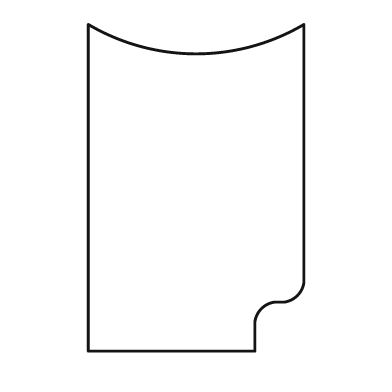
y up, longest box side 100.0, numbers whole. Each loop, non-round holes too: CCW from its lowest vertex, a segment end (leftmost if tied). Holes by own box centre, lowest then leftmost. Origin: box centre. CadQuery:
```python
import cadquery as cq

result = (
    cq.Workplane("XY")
    .moveTo(-33.0, -50.0)
    .lineTo(18.0, -50.0)
    .lineTo(18.0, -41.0)
    .threePointArc((20.0, -37.0), (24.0, -35.0))
    .lineTo(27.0, -35.0)
    .threePointArc((31.0, -33.0), (33.0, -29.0))
    .lineTo(33.0, 50.0)
    .threePointArc((0.0, 41.0), (-33.0, 50.0))
    .close()
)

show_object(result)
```